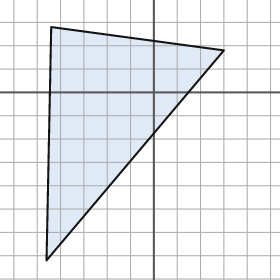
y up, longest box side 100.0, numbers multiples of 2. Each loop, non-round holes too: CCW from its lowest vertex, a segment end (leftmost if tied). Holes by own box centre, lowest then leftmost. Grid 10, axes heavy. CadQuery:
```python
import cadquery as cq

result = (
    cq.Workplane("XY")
    .moveTo(-46.0, -72.0)
    .lineTo(30.0, 18.0)
    .lineTo(-44.0, 28.0)
    .close()
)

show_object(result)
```